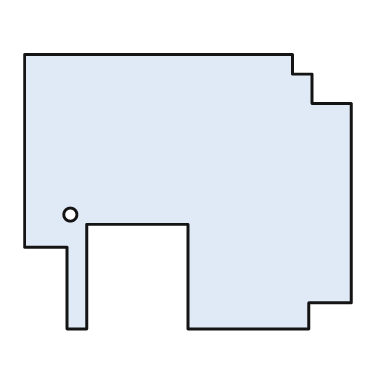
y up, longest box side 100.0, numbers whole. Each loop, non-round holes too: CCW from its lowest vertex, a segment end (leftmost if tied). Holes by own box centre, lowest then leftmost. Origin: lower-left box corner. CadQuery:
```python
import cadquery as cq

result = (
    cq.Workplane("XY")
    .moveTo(13.0, 0.0)
    .lineTo(19.0, 0.0)
    .lineTo(19.0, 32.0)
    .lineTo(50.0, 32.0)
    .lineTo(50.0, 0.0)
    .lineTo(87.0, 0.0)
    .lineTo(87.0, 8.0)
    .lineTo(100.0, 8.0)
    .lineTo(100.0, 69.0)
    .lineTo(88.0, 69.0)
    .lineTo(88.0, 78.0)
    .lineTo(82.0, 78.0)
    .lineTo(82.0, 84.0)
    .lineTo(0.0, 84.0)
    .lineTo(0.0, 25.0)
    .lineTo(13.0, 25.0)
    .close()
    .moveTo(14.0, 35.0)
    .circle(2.0)
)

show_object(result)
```